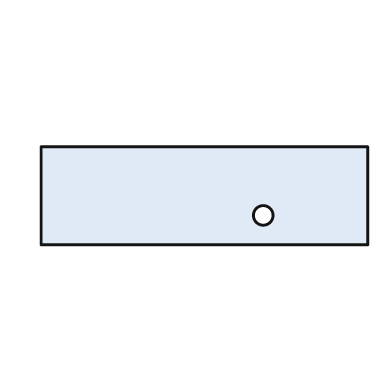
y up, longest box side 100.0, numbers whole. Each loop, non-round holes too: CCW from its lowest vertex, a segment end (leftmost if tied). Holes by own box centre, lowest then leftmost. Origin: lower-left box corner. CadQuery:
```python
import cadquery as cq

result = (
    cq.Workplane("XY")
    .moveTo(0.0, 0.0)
    .lineTo(100.0, 0.0)
    .lineTo(100.0, 30.0)
    .lineTo(0.0, 30.0)
    .close()
    .moveTo(68.0, 9.0)
    .circle(3.0)
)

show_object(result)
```